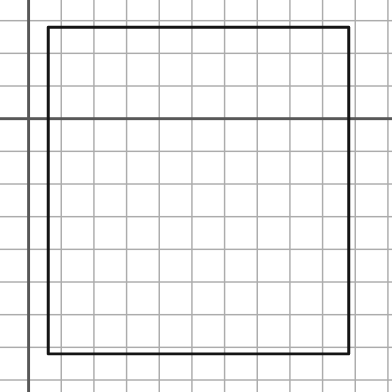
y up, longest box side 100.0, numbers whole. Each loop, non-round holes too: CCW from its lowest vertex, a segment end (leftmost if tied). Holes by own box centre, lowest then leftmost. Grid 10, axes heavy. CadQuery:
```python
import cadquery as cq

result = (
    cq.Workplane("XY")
    .moveTo(6.0, -72.0)
    .lineTo(98.0, -72.0)
    .lineTo(98.0, 28.0)
    .lineTo(6.0, 28.0)
    .close()
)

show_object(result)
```